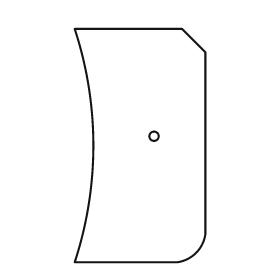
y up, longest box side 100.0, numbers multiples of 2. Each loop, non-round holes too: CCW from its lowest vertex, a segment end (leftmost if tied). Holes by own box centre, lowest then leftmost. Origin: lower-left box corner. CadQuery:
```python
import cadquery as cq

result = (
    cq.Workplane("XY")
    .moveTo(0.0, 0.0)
    .lineTo(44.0, 0.0)
    .threePointArc((52.0, 4.0), (56.0, 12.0))
    .lineTo(56.0, 90.0)
    .lineTo(46.0, 100.0)
    .lineTo(0.0, 100.0)
    .threePointArc((8.0, 50.0), (0.0, 0.0))
    .close()
    .moveTo(34.0, 54.0)
    .circle(2.0)
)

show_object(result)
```